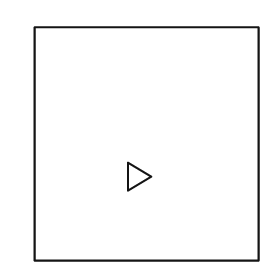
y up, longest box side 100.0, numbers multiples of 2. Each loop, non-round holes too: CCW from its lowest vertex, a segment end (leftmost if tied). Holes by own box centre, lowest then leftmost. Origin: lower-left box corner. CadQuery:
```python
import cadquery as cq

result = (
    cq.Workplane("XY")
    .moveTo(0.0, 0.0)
    .lineTo(96.0, 0.0)
    .lineTo(96.0, 100.0)
    .lineTo(0.0, 100.0)
    .close()
    .moveTo(40.0, 30.0)
    .lineTo(50.0, 36.0)
    .lineTo(40.0, 42.0)
    .close()
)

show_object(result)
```